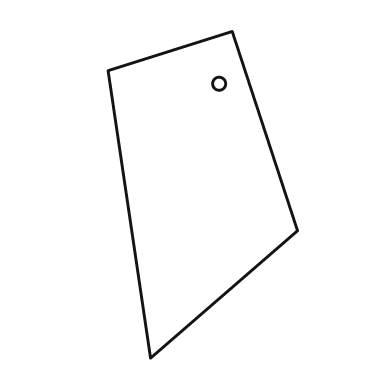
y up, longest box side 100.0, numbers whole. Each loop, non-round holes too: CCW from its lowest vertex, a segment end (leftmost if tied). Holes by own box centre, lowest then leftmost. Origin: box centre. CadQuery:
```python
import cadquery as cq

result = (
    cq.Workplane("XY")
    .moveTo(-16.0, -50.0)
    .lineTo(29.0, -11.0)
    .lineTo(9.0, 50.0)
    .lineTo(-29.0, 38.0)
    .close()
    .moveTo(5.0, 34.0)
    .circle(2.0)
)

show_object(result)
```